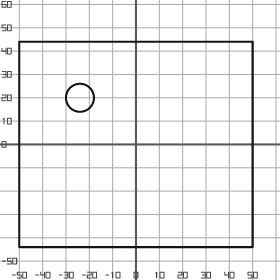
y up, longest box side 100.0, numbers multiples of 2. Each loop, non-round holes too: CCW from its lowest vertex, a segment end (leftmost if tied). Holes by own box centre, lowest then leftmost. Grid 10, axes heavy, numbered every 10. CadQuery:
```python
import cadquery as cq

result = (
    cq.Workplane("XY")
    .moveTo(-50.0, -44.0)
    .lineTo(50.0, -44.0)
    .lineTo(50.0, 44.0)
    .lineTo(-50.0, 44.0)
    .close()
    .moveTo(-24.0, 20.0)
    .circle(6.0)
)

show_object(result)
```